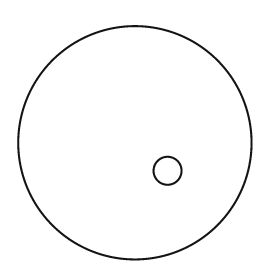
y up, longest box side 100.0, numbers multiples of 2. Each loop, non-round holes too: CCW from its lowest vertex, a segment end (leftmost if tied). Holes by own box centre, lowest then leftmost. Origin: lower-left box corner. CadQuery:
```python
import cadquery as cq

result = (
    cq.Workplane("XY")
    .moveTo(50.0, 50.0)
    .circle(50.0)
    .moveTo(64.0, 38.0)
    .circle(6.0)
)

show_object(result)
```